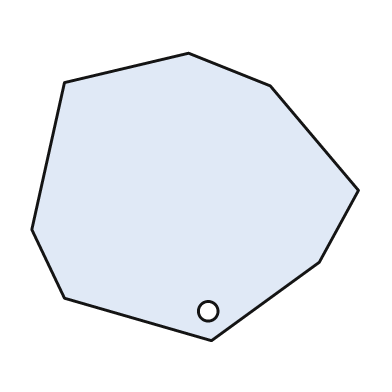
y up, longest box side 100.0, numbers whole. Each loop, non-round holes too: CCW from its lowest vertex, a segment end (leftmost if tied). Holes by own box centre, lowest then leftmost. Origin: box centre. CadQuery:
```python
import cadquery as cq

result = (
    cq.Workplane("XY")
    .moveTo(5.0, -44.0)
    .lineTo(38.0, -20.0)
    .lineTo(50.0, 2.0)
    .lineTo(23.0, 34.0)
    .lineTo(-2.0, 44.0)
    .lineTo(-40.0, 35.0)
    .lineTo(-50.0, -10.0)
    .lineTo(-40.0, -31.0)
    .close()
    .moveTo(4.0, -35.0)
    .circle(3.0)
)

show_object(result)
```